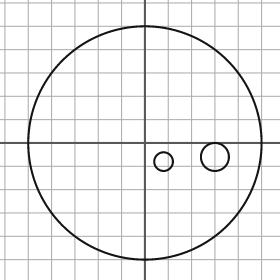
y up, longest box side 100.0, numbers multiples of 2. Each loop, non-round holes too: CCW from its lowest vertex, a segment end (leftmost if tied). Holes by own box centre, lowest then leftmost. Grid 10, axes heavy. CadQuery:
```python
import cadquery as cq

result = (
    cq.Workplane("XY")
    .moveTo(0.0, 0.0)
    .circle(50.0)
    .moveTo(8.0, -8.0)
    .circle(4.0)
    .moveTo(30.0, -6.0)
    .circle(6.0)
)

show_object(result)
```